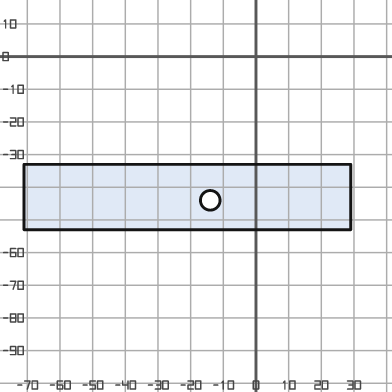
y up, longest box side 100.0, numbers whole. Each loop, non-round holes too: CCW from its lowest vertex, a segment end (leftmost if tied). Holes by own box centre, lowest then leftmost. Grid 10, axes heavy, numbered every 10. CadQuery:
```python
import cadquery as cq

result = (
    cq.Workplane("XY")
    .moveTo(-71.0, -53.0)
    .lineTo(29.0, -53.0)
    .lineTo(29.0, -33.0)
    .lineTo(-71.0, -33.0)
    .close()
    .moveTo(-14.0, -44.0)
    .circle(3.0)
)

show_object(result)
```